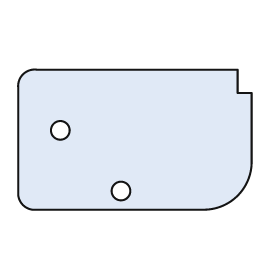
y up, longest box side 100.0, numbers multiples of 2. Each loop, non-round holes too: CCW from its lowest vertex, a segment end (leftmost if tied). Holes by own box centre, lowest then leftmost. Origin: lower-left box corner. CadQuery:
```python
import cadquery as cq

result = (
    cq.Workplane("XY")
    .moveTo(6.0, 0.0)
    .lineTo(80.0, 0.0)
    .threePointArc((94.0, 6.0), (100.0, 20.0))
    .lineTo(100.0, 50.0)
    .lineTo(94.0, 50.0)
    .lineTo(94.0, 60.0)
    .lineTo(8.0, 60.0)
    .threePointArc((2.0, 58.0), (0.0, 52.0))
    .lineTo(0.0, 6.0)
    .threePointArc((2.0, 2.0), (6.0, 0.0))
    .close()
    .moveTo(44.0, 8.0)
    .circle(4.0)
    .moveTo(18.0, 34.0)
    .circle(4.0)
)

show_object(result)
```